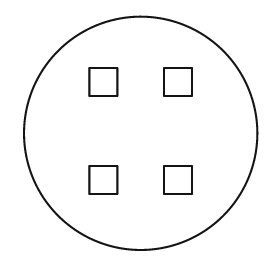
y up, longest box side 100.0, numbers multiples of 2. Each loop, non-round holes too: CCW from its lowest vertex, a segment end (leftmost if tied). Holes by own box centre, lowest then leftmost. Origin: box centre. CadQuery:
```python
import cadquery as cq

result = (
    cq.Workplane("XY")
    .moveTo(0.0, 0.0)
    .circle(50.0)
    .moveTo(-22.0, -26.0)
    .lineTo(-10.0, -26.0)
    .lineTo(-10.0, -14.0)
    .lineTo(-22.0, -14.0)
    .close()
    .moveTo(10.0, -26.0)
    .lineTo(22.0, -26.0)
    .lineTo(22.0, -14.0)
    .lineTo(10.0, -14.0)
    .close()
    .moveTo(-22.0, 16.0)
    .lineTo(-10.0, 16.0)
    .lineTo(-10.0, 28.0)
    .lineTo(-22.0, 28.0)
    .close()
    .moveTo(10.0, 16.0)
    .lineTo(22.0, 16.0)
    .lineTo(22.0, 28.0)
    .lineTo(10.0, 28.0)
    .close()
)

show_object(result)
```